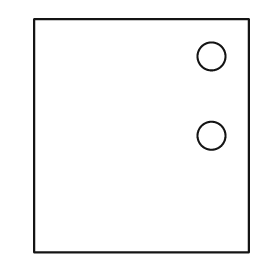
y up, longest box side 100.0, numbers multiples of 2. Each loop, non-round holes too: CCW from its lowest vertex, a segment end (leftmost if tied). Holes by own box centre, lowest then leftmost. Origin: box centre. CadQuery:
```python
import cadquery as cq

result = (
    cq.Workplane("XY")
    .moveTo(-46.0, -50.0)
    .lineTo(46.0, -50.0)
    .lineTo(46.0, 50.0)
    .lineTo(-46.0, 50.0)
    .close()
    .moveTo(30.0, 0.0)
    .circle(6.0)
    .moveTo(30.0, 34.0)
    .circle(6.0)
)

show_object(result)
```